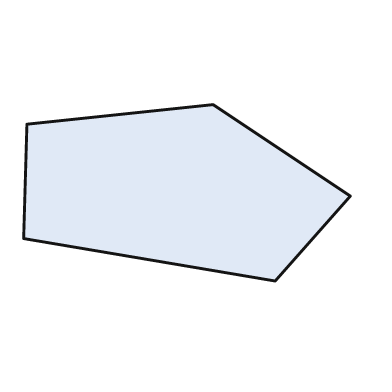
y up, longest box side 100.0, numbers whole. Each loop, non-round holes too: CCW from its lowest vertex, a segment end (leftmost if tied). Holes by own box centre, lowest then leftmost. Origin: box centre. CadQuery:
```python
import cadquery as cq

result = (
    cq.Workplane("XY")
    .moveTo(27.0, -27.0)
    .lineTo(50.0, -1.0)
    .lineTo(8.0, 27.0)
    .lineTo(-49.0, 21.0)
    .lineTo(-50.0, -14.0)
    .close()
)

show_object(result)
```